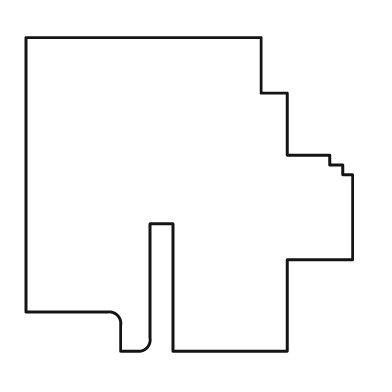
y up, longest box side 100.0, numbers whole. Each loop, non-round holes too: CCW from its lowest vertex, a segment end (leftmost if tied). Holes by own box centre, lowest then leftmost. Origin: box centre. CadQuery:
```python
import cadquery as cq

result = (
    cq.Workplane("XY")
    .moveTo(-21.0, -48.0)
    .lineTo(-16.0, -48.0)
    .threePointArc((-13.0, -47.0), (-12.0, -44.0))
    .lineTo(-12.0, -9.0)
    .lineTo(-5.0, -9.0)
    .lineTo(-5.0, -48.0)
    .lineTo(30.0, -48.0)
    .lineTo(30.0, -20.0)
    .lineTo(50.0, -20.0)
    .lineTo(50.0, 6.0)
    .lineTo(47.0, 6.0)
    .lineTo(47.0, 9.0)
    .lineTo(43.0, 9.0)
    .lineTo(43.0, 12.0)
    .lineTo(30.0, 12.0)
    .lineTo(30.0, 31.0)
    .lineTo(22.0, 31.0)
    .lineTo(22.0, 48.0)
    .lineTo(-50.0, 48.0)
    .lineTo(-50.0, -36.0)
    .lineTo(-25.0, -36.0)
    .threePointArc((-22.0, -37.0), (-21.0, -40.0))
    .close()
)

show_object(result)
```